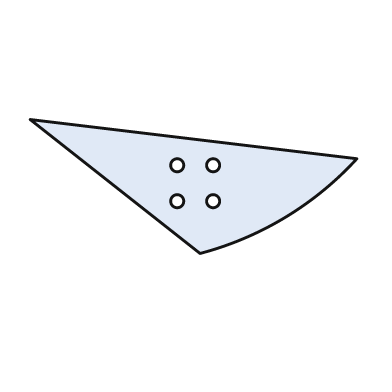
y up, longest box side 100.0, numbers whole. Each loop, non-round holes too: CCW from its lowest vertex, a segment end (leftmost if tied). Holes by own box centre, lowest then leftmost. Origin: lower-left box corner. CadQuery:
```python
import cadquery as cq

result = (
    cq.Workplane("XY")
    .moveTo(52.0, 0.0)
    .threePointArc((78.0, 11.0), (100.0, 29.0))
    .lineTo(0.0, 41.0)
    .close()
    .moveTo(45.0, 16.0)
    .circle(2.0)
    .moveTo(56.0, 16.0)
    .circle(2.0)
    .moveTo(45.0, 27.0)
    .circle(2.0)
    .moveTo(56.0, 27.0)
    .circle(2.0)
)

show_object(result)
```